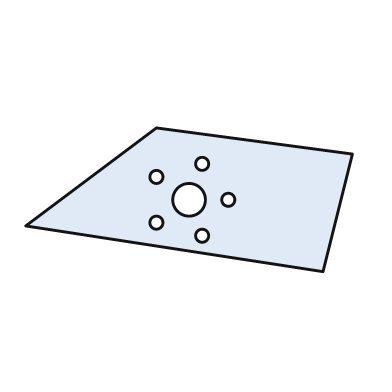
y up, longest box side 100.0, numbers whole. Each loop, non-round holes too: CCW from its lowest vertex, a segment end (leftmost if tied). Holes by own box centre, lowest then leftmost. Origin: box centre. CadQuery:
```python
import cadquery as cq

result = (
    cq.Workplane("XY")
    .moveTo(41.0, -22.0)
    .lineTo(50.0, 14.0)
    .lineTo(-10.0, 22.0)
    .lineTo(-50.0, -8.0)
    .close()
    .moveTo(4.0, -11.0)
    .circle(2.0)
    .moveTo(-10.0, -7.0)
    .circle(2.0)
    .moveTo(0.0, 0.0)
    .circle(5.0)
    .moveTo(12.0, 0.0)
    .circle(2.0)
    .moveTo(-10.0, 7.0)
    .circle(2.0)
    .moveTo(4.0, 11.0)
    .circle(2.0)
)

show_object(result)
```